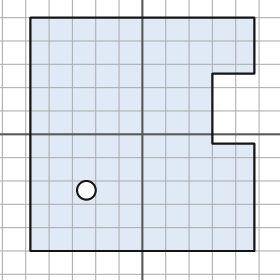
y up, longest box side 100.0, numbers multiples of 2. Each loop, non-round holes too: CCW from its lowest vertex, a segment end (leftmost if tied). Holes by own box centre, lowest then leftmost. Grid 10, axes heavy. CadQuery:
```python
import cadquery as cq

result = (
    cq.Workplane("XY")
    .moveTo(-48.0, -50.0)
    .lineTo(48.0, -50.0)
    .lineTo(48.0, -4.0)
    .lineTo(30.0, -4.0)
    .lineTo(30.0, 26.0)
    .lineTo(48.0, 26.0)
    .lineTo(48.0, 50.0)
    .lineTo(-48.0, 50.0)
    .close()
    .moveTo(-24.0, -24.0)
    .circle(4.0)
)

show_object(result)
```